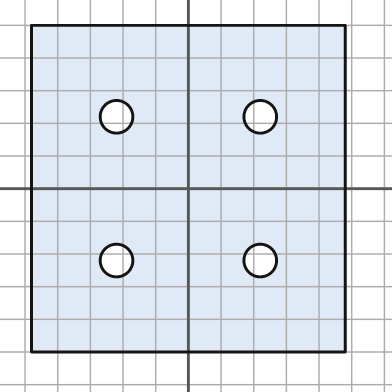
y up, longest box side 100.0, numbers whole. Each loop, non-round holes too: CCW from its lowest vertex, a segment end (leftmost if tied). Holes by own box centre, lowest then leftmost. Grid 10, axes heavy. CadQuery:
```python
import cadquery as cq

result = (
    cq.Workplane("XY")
    .moveTo(-48.0, -50.0)
    .lineTo(48.0, -50.0)
    .lineTo(48.0, 50.0)
    .lineTo(-48.0, 50.0)
    .close()
    .moveTo(-22.0, -22.0)
    .circle(5.0)
    .moveTo(22.0, -22.0)
    .circle(5.0)
    .moveTo(-22.0, 22.0)
    .circle(5.0)
    .moveTo(22.0, 22.0)
    .circle(5.0)
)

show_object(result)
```